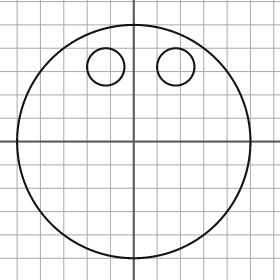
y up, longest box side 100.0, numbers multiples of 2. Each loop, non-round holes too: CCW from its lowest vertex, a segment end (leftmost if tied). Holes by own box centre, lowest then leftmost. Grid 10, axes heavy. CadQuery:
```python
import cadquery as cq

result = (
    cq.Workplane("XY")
    .moveTo(0.0, 0.0)
    .circle(50.0)
    .moveTo(-12.0, 32.0)
    .circle(8.0)
    .moveTo(18.0, 32.0)
    .circle(8.0)
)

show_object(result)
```